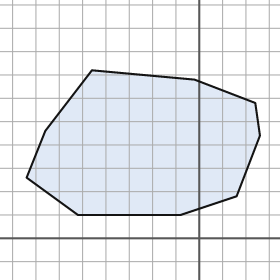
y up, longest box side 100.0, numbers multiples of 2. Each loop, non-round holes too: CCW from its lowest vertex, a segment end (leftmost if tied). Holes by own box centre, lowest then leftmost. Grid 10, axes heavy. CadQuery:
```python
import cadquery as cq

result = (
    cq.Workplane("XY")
    .moveTo(-52.0, 10.0)
    .lineTo(-8.0, 10.0)
    .lineTo(16.0, 18.0)
    .lineTo(26.0, 44.0)
    .lineTo(24.0, 58.0)
    .lineTo(-2.0, 68.0)
    .lineTo(-46.0, 72.0)
    .lineTo(-66.0, 46.0)
    .lineTo(-74.0, 26.0)
    .close()
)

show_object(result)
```